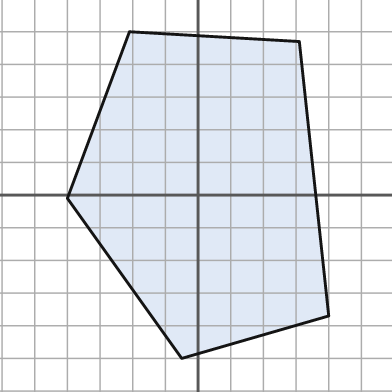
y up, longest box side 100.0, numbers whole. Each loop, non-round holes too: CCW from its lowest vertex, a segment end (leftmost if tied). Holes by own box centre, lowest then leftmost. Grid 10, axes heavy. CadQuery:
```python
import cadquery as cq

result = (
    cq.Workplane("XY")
    .moveTo(-5.0, -50.0)
    .lineTo(40.0, -37.0)
    .lineTo(31.0, 47.0)
    .lineTo(-21.0, 50.0)
    .lineTo(-40.0, -1.0)
    .close()
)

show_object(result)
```